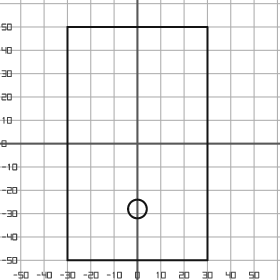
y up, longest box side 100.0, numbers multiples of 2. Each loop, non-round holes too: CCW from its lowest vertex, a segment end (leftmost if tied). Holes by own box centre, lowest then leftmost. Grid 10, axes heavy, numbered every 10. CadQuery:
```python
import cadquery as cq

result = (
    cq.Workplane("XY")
    .moveTo(-30.0, -50.0)
    .lineTo(30.0, -50.0)
    .lineTo(30.0, 50.0)
    .lineTo(-30.0, 50.0)
    .close()
    .moveTo(0.0, -28.0)
    .circle(4.0)
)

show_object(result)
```